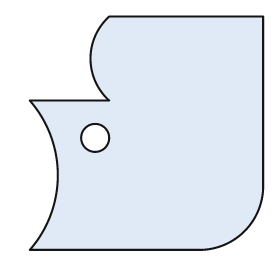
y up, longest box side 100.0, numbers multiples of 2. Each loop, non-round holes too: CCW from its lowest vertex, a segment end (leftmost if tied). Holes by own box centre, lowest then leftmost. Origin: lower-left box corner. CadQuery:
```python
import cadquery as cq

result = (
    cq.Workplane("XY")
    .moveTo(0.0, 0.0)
    .lineTo(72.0, 0.0)
    .threePointArc((92.0, 8.0), (100.0, 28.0))
    .lineTo(100.0, 100.0)
    .lineTo(34.0, 100.0)
    .threePointArc((26.0, 82.0), (34.0, 64.0))
    .lineTo(0.0, 64.0)
    .threePointArc((12.0, 32.0), (0.0, 0.0))
    .close()
    .moveTo(28.0, 48.0)
    .circle(6.0)
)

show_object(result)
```